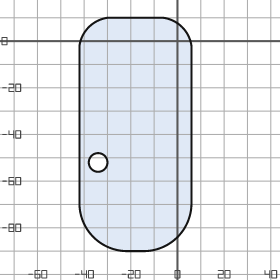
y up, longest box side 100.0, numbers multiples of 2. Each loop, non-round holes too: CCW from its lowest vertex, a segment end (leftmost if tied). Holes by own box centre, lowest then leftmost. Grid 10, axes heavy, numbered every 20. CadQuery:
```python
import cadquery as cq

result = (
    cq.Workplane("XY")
    .moveTo(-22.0, -90.0)
    .lineTo(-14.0, -90.0)
    .threePointArc((0.0, -84.0), (6.0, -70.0))
    .lineTo(6.0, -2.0)
    .threePointArc((2.0, 6.0), (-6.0, 10.0))
    .lineTo(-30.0, 10.0)
    .threePointArc((-38.0, 6.0), (-42.0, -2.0))
    .lineTo(-42.0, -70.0)
    .threePointArc((-36.0, -84.0), (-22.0, -90.0))
    .close()
    .moveTo(-34.0, -52.0)
    .circle(4.0)
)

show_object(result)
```